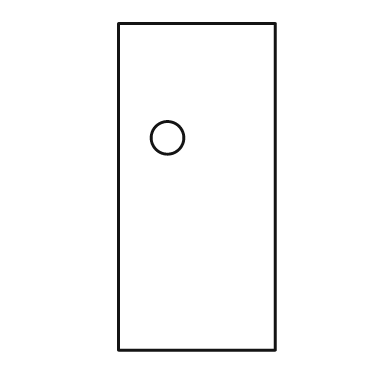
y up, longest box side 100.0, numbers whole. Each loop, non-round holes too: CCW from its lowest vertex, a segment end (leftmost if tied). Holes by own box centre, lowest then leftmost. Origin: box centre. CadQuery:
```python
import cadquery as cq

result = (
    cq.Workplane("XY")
    .moveTo(-24.0, -50.0)
    .lineTo(24.0, -50.0)
    .lineTo(24.0, 50.0)
    .lineTo(-24.0, 50.0)
    .close()
    .moveTo(-9.0, 15.0)
    .circle(5.0)
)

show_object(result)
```